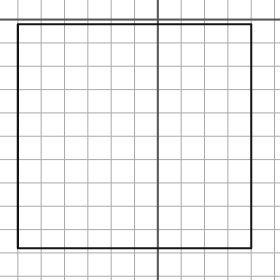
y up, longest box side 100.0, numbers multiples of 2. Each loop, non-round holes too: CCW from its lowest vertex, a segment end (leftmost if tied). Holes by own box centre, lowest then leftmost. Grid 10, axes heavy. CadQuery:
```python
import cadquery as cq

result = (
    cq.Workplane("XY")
    .moveTo(-60.0, -98.0)
    .lineTo(40.0, -98.0)
    .lineTo(40.0, -2.0)
    .lineTo(-60.0, -2.0)
    .close()
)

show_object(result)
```